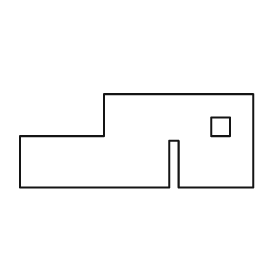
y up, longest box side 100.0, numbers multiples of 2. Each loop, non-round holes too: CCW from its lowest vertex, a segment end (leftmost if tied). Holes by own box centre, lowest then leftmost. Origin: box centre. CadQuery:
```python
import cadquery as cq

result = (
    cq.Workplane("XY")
    .moveTo(-50.0, -20.0)
    .lineTo(14.0, -20.0)
    .lineTo(14.0, 0.0)
    .lineTo(18.0, 0.0)
    .lineTo(18.0, -20.0)
    .lineTo(50.0, -20.0)
    .lineTo(50.0, 20.0)
    .lineTo(-14.0, 20.0)
    .lineTo(-14.0, 2.0)
    .lineTo(-50.0, 2.0)
    .close()
    .moveTo(32.0, 2.0)
    .lineTo(40.0, 2.0)
    .lineTo(40.0, 10.0)
    .lineTo(32.0, 10.0)
    .close()
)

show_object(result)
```